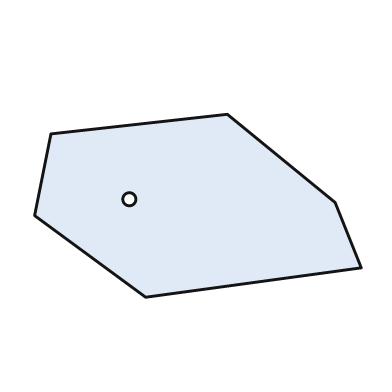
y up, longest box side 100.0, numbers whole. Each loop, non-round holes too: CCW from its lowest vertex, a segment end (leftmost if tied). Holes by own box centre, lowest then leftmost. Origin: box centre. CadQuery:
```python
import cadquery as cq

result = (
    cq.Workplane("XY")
    .moveTo(-16.0, -28.0)
    .lineTo(50.0, -19.0)
    .lineTo(42.0, 1.0)
    .lineTo(9.0, 28.0)
    .lineTo(-45.0, 22.0)
    .lineTo(-50.0, -3.0)
    .close()
    .moveTo(-21.0, 2.0)
    .circle(2.0)
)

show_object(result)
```